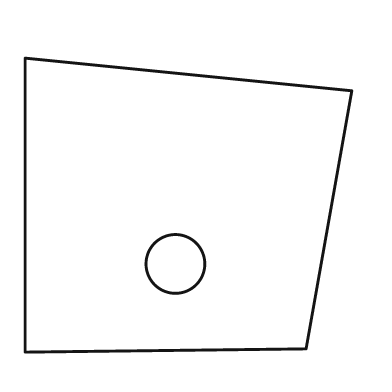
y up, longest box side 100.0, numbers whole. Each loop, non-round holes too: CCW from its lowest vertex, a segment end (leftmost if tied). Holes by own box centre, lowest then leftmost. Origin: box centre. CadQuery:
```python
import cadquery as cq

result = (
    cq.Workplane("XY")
    .moveTo(-50.0, -45.0)
    .lineTo(36.0, -44.0)
    .lineTo(50.0, 35.0)
    .lineTo(-50.0, 45.0)
    .close()
    .moveTo(-4.0, -18.0)
    .circle(9.0)
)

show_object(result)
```